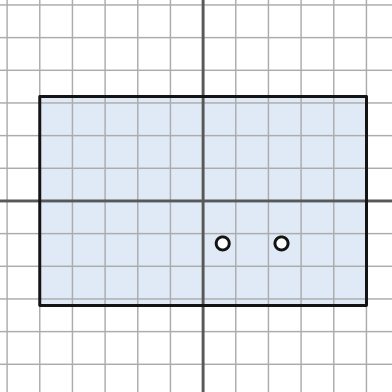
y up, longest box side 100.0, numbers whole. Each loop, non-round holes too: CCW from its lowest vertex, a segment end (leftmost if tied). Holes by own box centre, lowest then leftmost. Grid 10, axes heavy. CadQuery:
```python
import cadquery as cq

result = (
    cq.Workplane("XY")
    .moveTo(-50.0, -32.0)
    .lineTo(50.0, -32.0)
    .lineTo(50.0, 32.0)
    .lineTo(-50.0, 32.0)
    .close()
    .moveTo(6.0, -13.0)
    .circle(2.0)
    .moveTo(24.0, -13.0)
    .circle(2.0)
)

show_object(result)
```